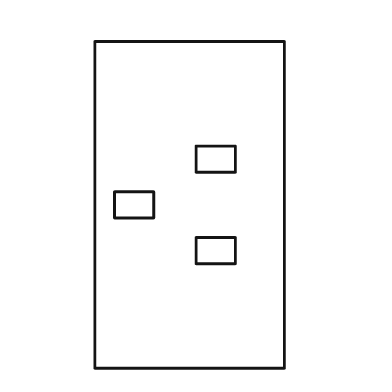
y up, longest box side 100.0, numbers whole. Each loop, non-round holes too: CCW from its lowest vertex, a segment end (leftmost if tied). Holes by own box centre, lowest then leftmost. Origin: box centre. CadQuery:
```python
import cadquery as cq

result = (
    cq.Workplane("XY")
    .moveTo(-29.0, -50.0)
    .lineTo(29.0, -50.0)
    .lineTo(29.0, 50.0)
    .lineTo(-29.0, 50.0)
    .close()
    .moveTo(2.0, -18.0)
    .lineTo(14.0, -18.0)
    .lineTo(14.0, -10.0)
    .lineTo(2.0, -10.0)
    .close()
    .moveTo(-23.0, -4.0)
    .lineTo(-11.0, -4.0)
    .lineTo(-11.0, 4.0)
    .lineTo(-23.0, 4.0)
    .close()
    .moveTo(2.0, 10.0)
    .lineTo(14.0, 10.0)
    .lineTo(14.0, 18.0)
    .lineTo(2.0, 18.0)
    .close()
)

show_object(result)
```